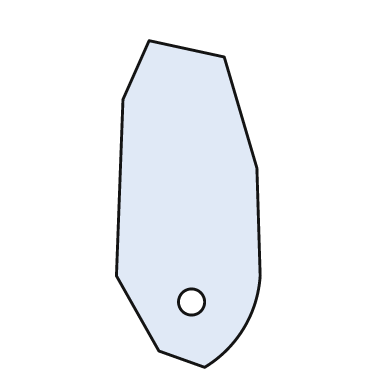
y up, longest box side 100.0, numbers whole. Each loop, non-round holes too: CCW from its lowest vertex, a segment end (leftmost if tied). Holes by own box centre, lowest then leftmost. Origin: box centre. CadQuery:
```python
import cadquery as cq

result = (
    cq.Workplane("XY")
    .moveTo(5.0, -50.0)
    .threePointArc((17.0, -38.0), (22.0, -22.0))
    .lineTo(21.0, 11.0)
    .lineTo(11.0, 45.0)
    .lineTo(-12.0, 50.0)
    .lineTo(-20.0, 32.0)
    .lineTo(-22.0, -22.0)
    .lineTo(-9.0, -45.0)
    .close()
    .moveTo(1.0, -30.0)
    .circle(4.0)
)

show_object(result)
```